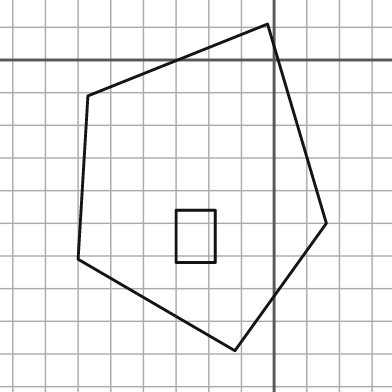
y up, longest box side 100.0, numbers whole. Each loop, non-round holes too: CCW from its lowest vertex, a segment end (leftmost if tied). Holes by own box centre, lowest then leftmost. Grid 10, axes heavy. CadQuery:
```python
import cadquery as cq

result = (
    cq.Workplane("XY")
    .moveTo(-12.0, -89.0)
    .lineTo(16.0, -50.0)
    .lineTo(-2.0, 11.0)
    .lineTo(-57.0, -11.0)
    .lineTo(-60.0, -61.0)
    .close()
    .moveTo(-30.0, -62.0)
    .lineTo(-18.0, -62.0)
    .lineTo(-18.0, -46.0)
    .lineTo(-30.0, -46.0)
    .close()
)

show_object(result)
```